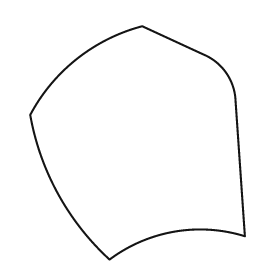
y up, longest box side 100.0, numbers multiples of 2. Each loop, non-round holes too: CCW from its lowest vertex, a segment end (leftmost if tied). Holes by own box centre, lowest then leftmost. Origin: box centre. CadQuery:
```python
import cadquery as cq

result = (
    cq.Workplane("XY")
    .moveTo(-12.0, -50.0)
    .threePointArc((16.0, -38.0), (46.0, -40.0))
    .lineTo(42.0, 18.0)
    .threePointArc((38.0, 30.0), (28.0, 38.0))
    .lineTo(2.0, 50.0)
    .threePointArc((-26.0, 36.0), (-46.0, 12.0))
    .threePointArc((-34.0, -22.0), (-12.0, -50.0))
    .close()
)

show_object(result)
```